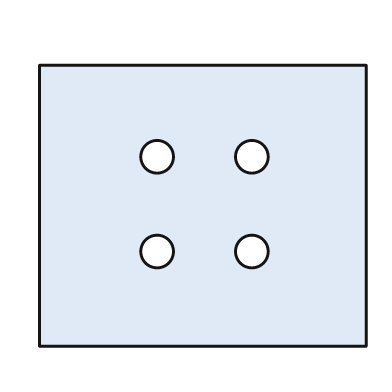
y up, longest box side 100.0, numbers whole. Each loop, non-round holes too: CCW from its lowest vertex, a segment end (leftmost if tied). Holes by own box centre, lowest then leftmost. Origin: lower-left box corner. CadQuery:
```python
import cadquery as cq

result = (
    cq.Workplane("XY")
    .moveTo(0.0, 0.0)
    .lineTo(100.0, 0.0)
    .lineTo(100.0, 86.0)
    .lineTo(0.0, 86.0)
    .close()
    .moveTo(36.0, 29.0)
    .circle(5.0)
    .moveTo(65.0, 29.0)
    .circle(5.0)
    .moveTo(36.0, 58.0)
    .circle(5.0)
    .moveTo(65.0, 58.0)
    .circle(5.0)
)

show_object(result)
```